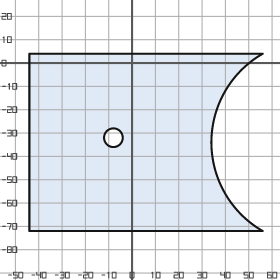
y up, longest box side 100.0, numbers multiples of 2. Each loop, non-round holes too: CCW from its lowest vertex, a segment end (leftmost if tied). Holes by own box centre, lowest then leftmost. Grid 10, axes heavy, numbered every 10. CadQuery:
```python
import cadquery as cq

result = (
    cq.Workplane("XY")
    .moveTo(-44.0, -72.0)
    .lineTo(56.0, -72.0)
    .threePointArc((34.0, -34.0), (56.0, 4.0))
    .lineTo(-44.0, 4.0)
    .close()
    .moveTo(-8.0, -32.0)
    .circle(4.0)
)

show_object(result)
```